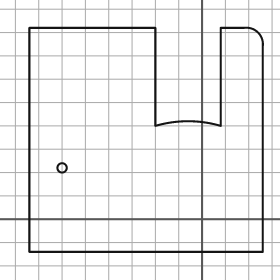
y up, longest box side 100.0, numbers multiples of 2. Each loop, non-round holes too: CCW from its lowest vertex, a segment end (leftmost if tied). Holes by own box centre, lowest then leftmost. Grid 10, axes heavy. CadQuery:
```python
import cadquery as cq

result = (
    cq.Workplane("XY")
    .moveTo(-74.0, -14.0)
    .lineTo(26.0, -14.0)
    .lineTo(26.0, 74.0)
    .threePointArc((24.0, 80.0), (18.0, 82.0))
    .lineTo(8.0, 82.0)
    .lineTo(8.0, 40.0)
    .threePointArc((-6.0, 42.0), (-20.0, 40.0))
    .lineTo(-20.0, 82.0)
    .lineTo(-74.0, 82.0)
    .close()
    .moveTo(-60.0, 22.0)
    .circle(2.0)
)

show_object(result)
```